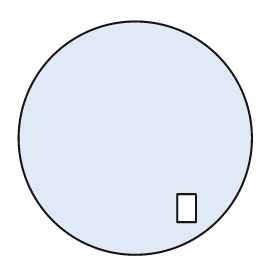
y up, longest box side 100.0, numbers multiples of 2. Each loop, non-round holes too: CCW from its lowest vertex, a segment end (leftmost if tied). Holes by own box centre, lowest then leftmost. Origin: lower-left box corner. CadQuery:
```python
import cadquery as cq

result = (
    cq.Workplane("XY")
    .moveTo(50.0, 50.0)
    .circle(50.0)
    .moveTo(68.0, 14.0)
    .lineTo(76.0, 14.0)
    .lineTo(76.0, 26.0)
    .lineTo(68.0, 26.0)
    .close()
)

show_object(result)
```